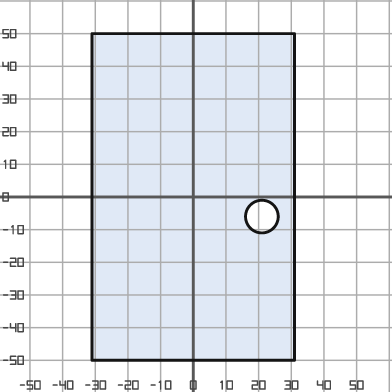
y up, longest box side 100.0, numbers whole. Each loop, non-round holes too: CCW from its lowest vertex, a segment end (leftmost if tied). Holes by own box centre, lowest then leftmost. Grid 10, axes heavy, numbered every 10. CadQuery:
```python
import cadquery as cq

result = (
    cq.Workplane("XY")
    .moveTo(-31.0, -50.0)
    .lineTo(31.0, -50.0)
    .lineTo(31.0, 50.0)
    .lineTo(-31.0, 50.0)
    .close()
    .moveTo(21.0, -6.0)
    .circle(5.0)
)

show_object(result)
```